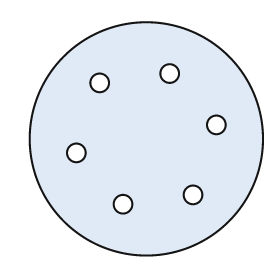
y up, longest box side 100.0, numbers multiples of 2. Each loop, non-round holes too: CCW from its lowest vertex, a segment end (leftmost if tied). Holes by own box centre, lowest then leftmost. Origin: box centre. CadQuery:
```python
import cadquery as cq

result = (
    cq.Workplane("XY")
    .moveTo(0.0, 0.0)
    .circle(50.0)
    .moveTo(-10.0, -28.0)
    .circle(4.0)
    .moveTo(20.0, -24.0)
    .circle(4.0)
    .moveTo(-30.0, -6.0)
    .circle(4.0)
    .moveTo(30.0, 6.0)
    .circle(4.0)
    .moveTo(-20.0, 24.0)
    .circle(4.0)
    .moveTo(10.0, 28.0)
    .circle(4.0)
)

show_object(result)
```